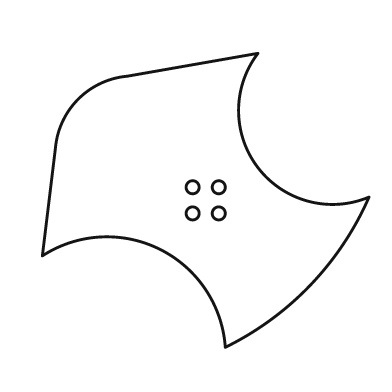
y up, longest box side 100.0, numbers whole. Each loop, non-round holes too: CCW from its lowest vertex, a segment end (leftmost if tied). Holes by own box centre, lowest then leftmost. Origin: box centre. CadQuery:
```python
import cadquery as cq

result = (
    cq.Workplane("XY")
    .moveTo(6.0, -45.0)
    .threePointArc((32.0, -26.0), (50.0, 1.0))
    .threePointArc((16.0, 10.0), (16.0, 45.0))
    .lineTo(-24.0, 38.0)
    .threePointArc((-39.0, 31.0), (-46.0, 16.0))
    .lineTo(-50.0, -17.0)
    .threePointArc((-14.0, -15.0), (6.0, -45.0))
    .close()
    .moveTo(-4.0, -4.0)
    .circle(2.0)
    .moveTo(4.0, -4.0)
    .circle(2.0)
    .moveTo(-4.0, 4.0)
    .circle(2.0)
    .moveTo(4.0, 4.0)
    .circle(2.0)
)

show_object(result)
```